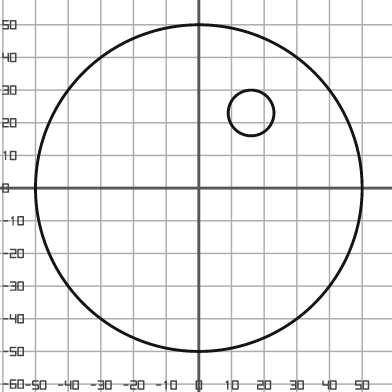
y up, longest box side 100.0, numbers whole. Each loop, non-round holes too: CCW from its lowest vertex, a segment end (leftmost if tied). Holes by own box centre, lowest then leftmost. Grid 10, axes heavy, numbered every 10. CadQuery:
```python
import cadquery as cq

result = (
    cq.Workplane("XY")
    .moveTo(0.0, 0.0)
    .circle(50.0)
    .moveTo(16.0, 23.0)
    .circle(7.0)
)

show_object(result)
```